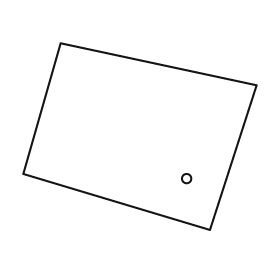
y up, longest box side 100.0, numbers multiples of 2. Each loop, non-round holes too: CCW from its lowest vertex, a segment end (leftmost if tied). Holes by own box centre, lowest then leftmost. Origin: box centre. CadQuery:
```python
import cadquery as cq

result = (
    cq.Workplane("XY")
    .moveTo(30.0, -40.0)
    .lineTo(50.0, 22.0)
    .lineTo(-34.0, 40.0)
    .lineTo(-50.0, -16.0)
    .close()
    .moveTo(20.0, -18.0)
    .circle(2.0)
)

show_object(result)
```